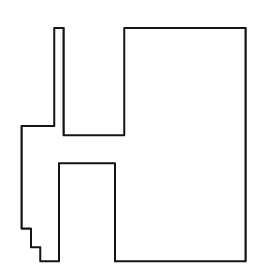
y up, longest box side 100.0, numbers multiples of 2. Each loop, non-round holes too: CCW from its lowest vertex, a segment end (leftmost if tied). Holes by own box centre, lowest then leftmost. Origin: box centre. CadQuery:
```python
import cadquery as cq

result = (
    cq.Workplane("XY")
    .moveTo(-40.0, -50.0)
    .lineTo(-32.0, -50.0)
    .lineTo(-32.0, -8.0)
    .lineTo(-8.0, -8.0)
    .lineTo(-8.0, -50.0)
    .lineTo(48.0, -50.0)
    .lineTo(48.0, 50.0)
    .lineTo(-4.0, 50.0)
    .lineTo(-4.0, 4.0)
    .lineTo(-30.0, 4.0)
    .lineTo(-30.0, 50.0)
    .lineTo(-34.0, 50.0)
    .lineTo(-34.0, 8.0)
    .lineTo(-48.0, 8.0)
    .lineTo(-48.0, -36.0)
    .lineTo(-44.0, -36.0)
    .lineTo(-44.0, -44.0)
    .lineTo(-40.0, -44.0)
    .close()
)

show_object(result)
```